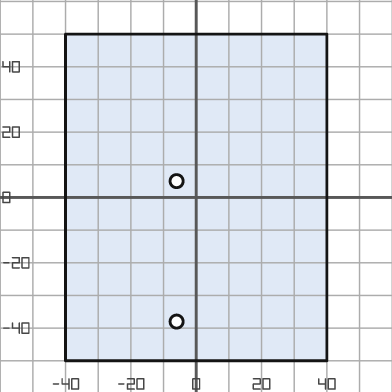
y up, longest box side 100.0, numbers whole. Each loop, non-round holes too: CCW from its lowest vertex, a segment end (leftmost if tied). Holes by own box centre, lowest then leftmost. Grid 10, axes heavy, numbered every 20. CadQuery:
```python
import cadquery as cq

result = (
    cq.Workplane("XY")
    .moveTo(-40.0, -50.0)
    .lineTo(40.0, -50.0)
    .lineTo(40.0, 50.0)
    .lineTo(-40.0, 50.0)
    .close()
    .moveTo(-6.0, -38.0)
    .circle(2.0)
    .moveTo(-6.0, 5.0)
    .circle(2.0)
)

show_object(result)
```